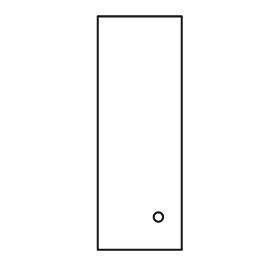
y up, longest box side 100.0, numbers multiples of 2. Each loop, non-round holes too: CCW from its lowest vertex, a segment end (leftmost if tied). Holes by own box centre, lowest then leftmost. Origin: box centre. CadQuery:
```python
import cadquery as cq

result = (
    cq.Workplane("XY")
    .moveTo(-18.0, -50.0)
    .lineTo(18.0, -50.0)
    .lineTo(18.0, 50.0)
    .lineTo(-18.0, 50.0)
    .close()
    .moveTo(8.0, -36.0)
    .circle(2.0)
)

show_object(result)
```